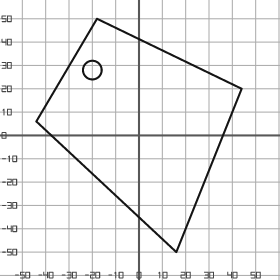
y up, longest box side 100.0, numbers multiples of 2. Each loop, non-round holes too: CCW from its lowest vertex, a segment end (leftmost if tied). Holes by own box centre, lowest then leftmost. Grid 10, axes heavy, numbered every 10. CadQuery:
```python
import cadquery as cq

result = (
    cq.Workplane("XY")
    .moveTo(16.0, -50.0)
    .lineTo(44.0, 20.0)
    .lineTo(-18.0, 50.0)
    .lineTo(-44.0, 6.0)
    .close()
    .moveTo(-20.0, 28.0)
    .circle(4.0)
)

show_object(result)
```